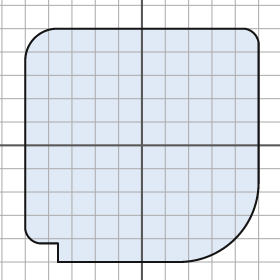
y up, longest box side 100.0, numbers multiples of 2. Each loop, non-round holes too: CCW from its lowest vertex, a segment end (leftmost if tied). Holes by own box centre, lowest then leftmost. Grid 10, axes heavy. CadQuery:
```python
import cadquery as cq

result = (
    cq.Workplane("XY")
    .moveTo(-36.0, -50.0)
    .lineTo(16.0, -50.0)
    .threePointArc((40.0, -40.0), (50.0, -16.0))
    .lineTo(50.0, 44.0)
    .threePointArc((48.0, 48.0), (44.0, 50.0))
    .lineTo(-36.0, 50.0)
    .threePointArc((-46.0, 46.0), (-50.0, 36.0))
    .lineTo(-50.0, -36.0)
    .threePointArc((-48.0, -40.0), (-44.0, -42.0))
    .lineTo(-36.0, -42.0)
    .close()
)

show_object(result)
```